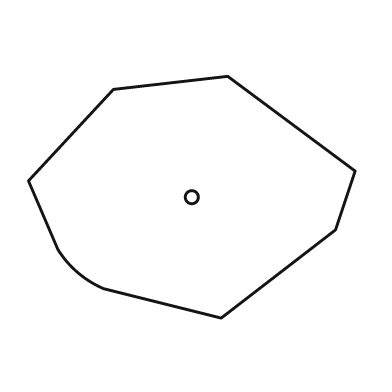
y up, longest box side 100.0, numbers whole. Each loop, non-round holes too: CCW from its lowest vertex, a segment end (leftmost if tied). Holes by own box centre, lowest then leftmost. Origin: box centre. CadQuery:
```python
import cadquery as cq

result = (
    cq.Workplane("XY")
    .moveTo(9.0, -37.0)
    .lineTo(44.0, -10.0)
    .lineTo(50.0, 8.0)
    .lineTo(11.0, 37.0)
    .lineTo(-24.0, 33.0)
    .lineTo(-50.0, 5.0)
    .lineTo(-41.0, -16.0)
    .threePointArc((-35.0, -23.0), (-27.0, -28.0))
    .close()
    .moveTo(0.0, 0.0)
    .circle(2.0)
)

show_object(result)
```